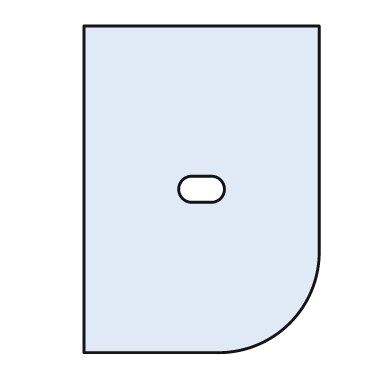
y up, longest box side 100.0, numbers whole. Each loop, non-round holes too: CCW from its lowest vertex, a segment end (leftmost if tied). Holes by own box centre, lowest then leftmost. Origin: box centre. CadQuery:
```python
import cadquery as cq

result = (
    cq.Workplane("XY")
    .moveTo(-36.0, -50.0)
    .lineTo(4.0, -50.0)
    .threePointArc((27.0, -41.0), (36.0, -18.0))
    .lineTo(36.0, 50.0)
    .lineTo(-36.0, 50.0)
    .close()
    .moveTo(-3.0, -4.0)
    .lineTo(3.0, -4.0)
    .threePointArc((7.0, 0.0), (3.0, 4.0))
    .lineTo(-3.0, 4.0)
    .threePointArc((-7.0, 0.0), (-3.0, -4.0))
    .close()
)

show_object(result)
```